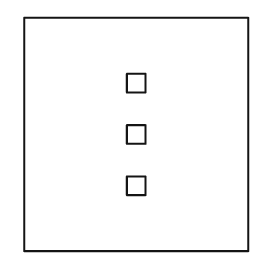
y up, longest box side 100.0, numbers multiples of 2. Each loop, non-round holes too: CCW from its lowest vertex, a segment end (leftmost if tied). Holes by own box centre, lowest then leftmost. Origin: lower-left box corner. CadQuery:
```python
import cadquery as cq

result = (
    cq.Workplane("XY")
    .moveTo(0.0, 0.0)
    .lineTo(96.0, 0.0)
    .lineTo(96.0, 100.0)
    .lineTo(0.0, 100.0)
    .close()
    .moveTo(44.0, 24.0)
    .lineTo(52.0, 24.0)
    .lineTo(52.0, 32.0)
    .lineTo(44.0, 32.0)
    .close()
    .moveTo(44.0, 46.0)
    .lineTo(52.0, 46.0)
    .lineTo(52.0, 54.0)
    .lineTo(44.0, 54.0)
    .close()
    .moveTo(44.0, 68.0)
    .lineTo(52.0, 68.0)
    .lineTo(52.0, 76.0)
    .lineTo(44.0, 76.0)
    .close()
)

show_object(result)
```